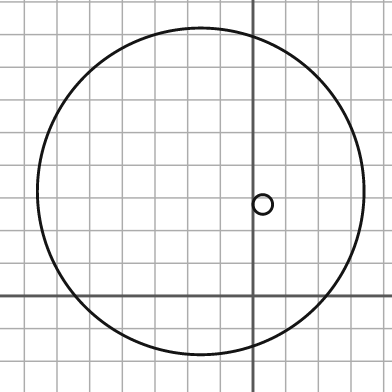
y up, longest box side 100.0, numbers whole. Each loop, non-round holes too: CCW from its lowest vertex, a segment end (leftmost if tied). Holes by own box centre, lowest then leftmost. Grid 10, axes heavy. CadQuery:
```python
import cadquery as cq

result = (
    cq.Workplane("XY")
    .moveTo(-16.0, 32.0)
    .circle(50.0)
    .moveTo(3.0, 28.0)
    .circle(3.0)
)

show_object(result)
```